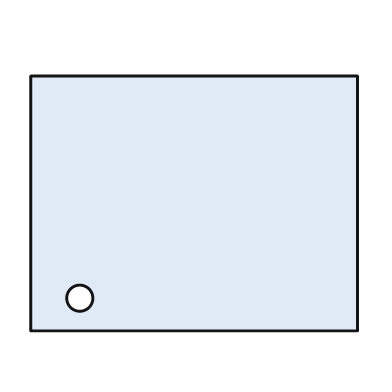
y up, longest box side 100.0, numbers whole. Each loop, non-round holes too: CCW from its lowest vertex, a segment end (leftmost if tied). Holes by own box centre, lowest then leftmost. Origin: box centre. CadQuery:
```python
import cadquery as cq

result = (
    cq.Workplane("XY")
    .moveTo(-50.0, -39.0)
    .lineTo(50.0, -39.0)
    .lineTo(50.0, 39.0)
    .lineTo(-50.0, 39.0)
    .close()
    .moveTo(-35.0, -29.0)
    .circle(4.0)
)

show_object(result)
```